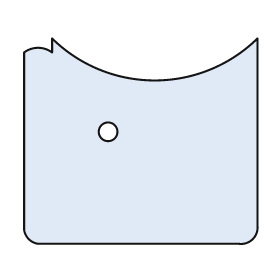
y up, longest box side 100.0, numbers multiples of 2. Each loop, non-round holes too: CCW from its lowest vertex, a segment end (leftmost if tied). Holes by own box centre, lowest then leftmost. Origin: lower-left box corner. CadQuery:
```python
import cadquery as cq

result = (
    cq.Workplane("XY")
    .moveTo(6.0, 0.0)
    .lineTo(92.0, 0.0)
    .threePointArc((98.0, 2.0), (100.0, 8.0))
    .lineTo(100.0, 88.0)
    .threePointArc((56.0, 70.0), (12.0, 88.0))
    .lineTo(12.0, 82.0)
    .threePointArc((6.0, 84.0), (0.0, 82.0))
    .lineTo(0.0, 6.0)
    .threePointArc((2.0, 2.0), (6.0, 0.0))
    .close()
    .moveTo(36.0, 48.0)
    .circle(4.0)
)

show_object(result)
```